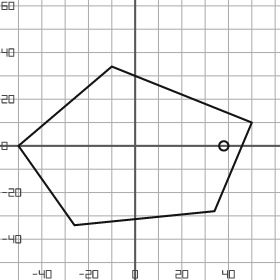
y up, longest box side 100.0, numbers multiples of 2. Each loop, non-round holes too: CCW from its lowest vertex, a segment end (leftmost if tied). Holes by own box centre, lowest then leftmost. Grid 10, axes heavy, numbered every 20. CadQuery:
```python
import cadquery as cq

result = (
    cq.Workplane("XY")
    .moveTo(-26.0, -34.0)
    .lineTo(34.0, -28.0)
    .lineTo(50.0, 10.0)
    .lineTo(-10.0, 34.0)
    .lineTo(-50.0, 0.0)
    .close()
    .moveTo(38.0, 0.0)
    .circle(2.0)
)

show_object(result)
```